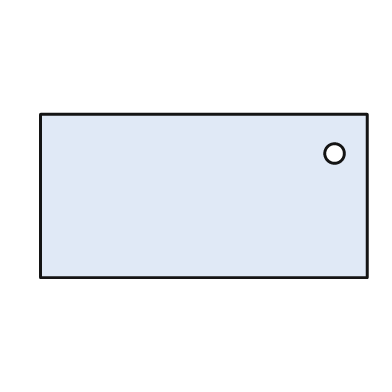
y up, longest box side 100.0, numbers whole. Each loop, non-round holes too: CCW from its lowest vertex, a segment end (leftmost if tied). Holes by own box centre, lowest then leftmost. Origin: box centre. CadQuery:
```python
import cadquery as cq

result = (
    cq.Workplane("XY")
    .moveTo(-50.0, -25.0)
    .lineTo(50.0, -25.0)
    .lineTo(50.0, 25.0)
    .lineTo(-50.0, 25.0)
    .close()
    .moveTo(40.0, 13.0)
    .circle(3.0)
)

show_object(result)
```